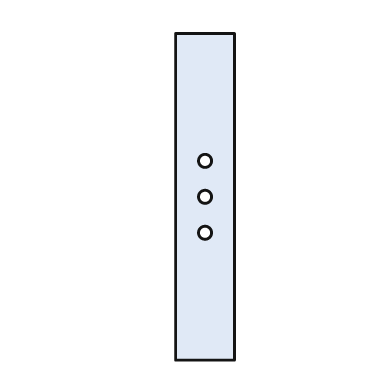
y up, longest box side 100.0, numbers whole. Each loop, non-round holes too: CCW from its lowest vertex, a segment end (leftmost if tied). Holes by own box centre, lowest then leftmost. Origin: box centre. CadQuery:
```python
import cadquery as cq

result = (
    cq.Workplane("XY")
    .moveTo(-9.0, -50.0)
    .lineTo(9.0, -50.0)
    .lineTo(9.0, 50.0)
    .lineTo(-9.0, 50.0)
    .close()
    .moveTo(0.0, -11.0)
    .circle(2.0)
    .moveTo(0.0, 0.0)
    .circle(2.0)
    .moveTo(0.0, 11.0)
    .circle(2.0)
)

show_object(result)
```